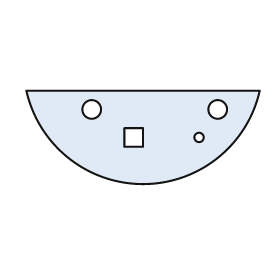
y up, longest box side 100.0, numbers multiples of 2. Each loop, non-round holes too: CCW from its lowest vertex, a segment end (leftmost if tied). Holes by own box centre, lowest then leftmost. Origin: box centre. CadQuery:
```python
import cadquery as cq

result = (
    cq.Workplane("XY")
    .moveTo(-50.0, 20.0)
    .threePointArc((0.0, -20.0), (50.0, 20.0))
    .close()
    .moveTo(-8.0, -4.0)
    .lineTo(0.0, -4.0)
    .lineTo(0.0, 4.0)
    .lineTo(-8.0, 4.0)
    .close()
    .moveTo(24.0, 0.0)
    .circle(2.0)
    .moveTo(-22.0, 12.0)
    .circle(4.0)
    .moveTo(32.0, 12.0)
    .circle(4.0)
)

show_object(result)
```